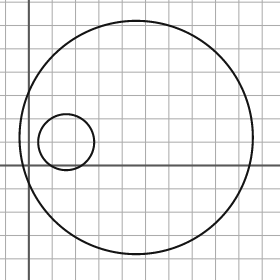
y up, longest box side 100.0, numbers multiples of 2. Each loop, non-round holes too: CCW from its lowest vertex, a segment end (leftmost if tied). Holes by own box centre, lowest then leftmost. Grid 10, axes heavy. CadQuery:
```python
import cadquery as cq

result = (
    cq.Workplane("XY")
    .moveTo(46.0, 12.0)
    .circle(50.0)
    .moveTo(16.0, 10.0)
    .circle(12.0)
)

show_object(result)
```